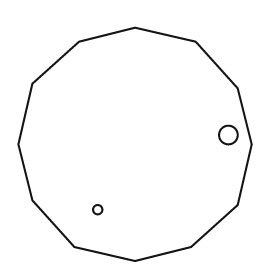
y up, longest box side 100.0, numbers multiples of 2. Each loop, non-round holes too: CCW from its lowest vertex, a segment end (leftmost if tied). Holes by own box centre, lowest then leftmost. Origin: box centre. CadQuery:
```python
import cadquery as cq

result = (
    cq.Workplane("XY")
    .moveTo(0.0, -50.0)
    .lineTo(24.0, -44.0)
    .lineTo(44.0, -26.0)
    .lineTo(50.0, 0.0)
    .lineTo(44.0, 24.0)
    .lineTo(26.0, 44.0)
    .lineTo(0.0, 50.0)
    .lineTo(-24.0, 44.0)
    .lineTo(-44.0, 26.0)
    .lineTo(-50.0, 0.0)
    .lineTo(-44.0, -24.0)
    .lineTo(-26.0, -44.0)
    .close()
    .moveTo(-16.0, -28.0)
    .circle(2.0)
    .moveTo(40.0, 4.0)
    .circle(4.0)
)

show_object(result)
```